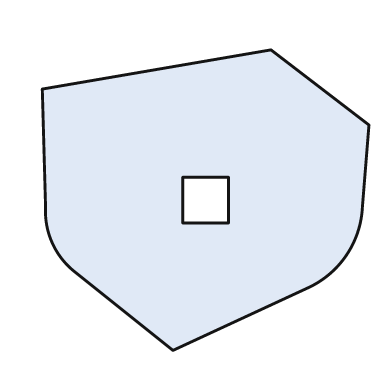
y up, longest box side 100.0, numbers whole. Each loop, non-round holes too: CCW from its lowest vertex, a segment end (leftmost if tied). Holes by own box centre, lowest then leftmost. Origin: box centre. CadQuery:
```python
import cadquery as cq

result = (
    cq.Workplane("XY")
    .moveTo(-10.0, -46.0)
    .lineTo(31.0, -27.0)
    .threePointArc((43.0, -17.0), (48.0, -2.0))
    .lineTo(50.0, 23.0)
    .lineTo(20.0, 46.0)
    .lineTo(-50.0, 34.0)
    .lineTo(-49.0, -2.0)
    .threePointArc((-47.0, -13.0), (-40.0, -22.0))
    .close()
    .moveTo(-7.0, -7.0)
    .lineTo(7.0, -7.0)
    .lineTo(7.0, 7.0)
    .lineTo(-7.0, 7.0)
    .close()
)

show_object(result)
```